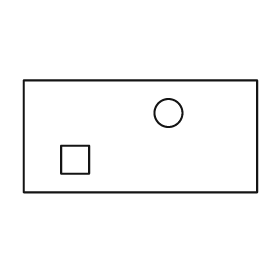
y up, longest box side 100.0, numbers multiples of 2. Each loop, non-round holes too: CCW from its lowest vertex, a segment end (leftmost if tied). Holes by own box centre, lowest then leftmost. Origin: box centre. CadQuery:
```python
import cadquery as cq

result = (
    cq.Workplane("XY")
    .moveTo(-50.0, -24.0)
    .lineTo(50.0, -24.0)
    .lineTo(50.0, 24.0)
    .lineTo(-50.0, 24.0)
    .close()
    .moveTo(-34.0, -16.0)
    .lineTo(-22.0, -16.0)
    .lineTo(-22.0, -4.0)
    .lineTo(-34.0, -4.0)
    .close()
    .moveTo(12.0, 10.0)
    .circle(6.0)
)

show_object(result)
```